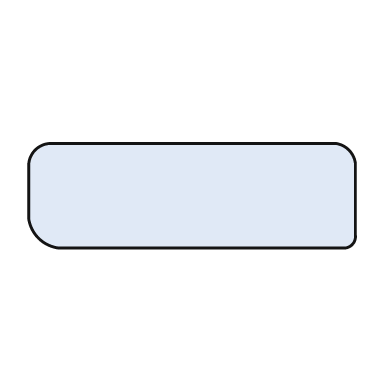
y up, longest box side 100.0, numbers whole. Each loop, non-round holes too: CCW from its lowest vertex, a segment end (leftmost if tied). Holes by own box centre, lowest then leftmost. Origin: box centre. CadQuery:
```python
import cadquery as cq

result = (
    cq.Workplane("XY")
    .moveTo(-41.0, -16.0)
    .lineTo(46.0, -16.0)
    .threePointArc((49.0, -15.0), (50.0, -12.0))
    .lineTo(50.0, 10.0)
    .threePointArc((48.0, 14.0), (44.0, 16.0))
    .lineTo(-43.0, 16.0)
    .threePointArc((-48.0, 14.0), (-50.0, 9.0))
    .lineTo(-50.0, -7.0)
    .threePointArc((-47.0, -13.0), (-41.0, -16.0))
    .close()
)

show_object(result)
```